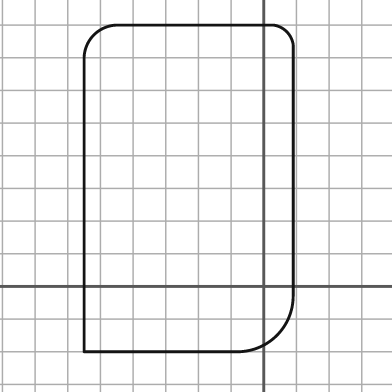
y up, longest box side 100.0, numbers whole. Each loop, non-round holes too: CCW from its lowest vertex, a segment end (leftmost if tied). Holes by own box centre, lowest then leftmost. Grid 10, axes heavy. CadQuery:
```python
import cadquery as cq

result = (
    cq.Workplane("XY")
    .moveTo(-55.0, -20.0)
    .lineTo(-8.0, -20.0)
    .threePointArc((4.0, -15.0), (9.0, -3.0))
    .lineTo(9.0, 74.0)
    .threePointArc((7.0, 78.0), (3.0, 80.0))
    .lineTo(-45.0, 80.0)
    .threePointArc((-52.0, 77.0), (-55.0, 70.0))
    .close()
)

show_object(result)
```